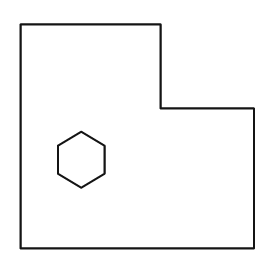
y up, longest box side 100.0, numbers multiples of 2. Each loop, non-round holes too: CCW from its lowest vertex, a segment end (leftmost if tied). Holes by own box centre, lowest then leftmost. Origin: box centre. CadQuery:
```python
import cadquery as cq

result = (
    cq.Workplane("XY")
    .moveTo(-50.0, -48.0)
    .lineTo(50.0, -48.0)
    .lineTo(50.0, 12.0)
    .lineTo(10.0, 12.0)
    .lineTo(10.0, 48.0)
    .lineTo(-50.0, 48.0)
    .close()
    .moveTo(-24.0, -22.0)
    .lineTo(-14.0, -16.0)
    .lineTo(-14.0, -4.0)
    .lineTo(-24.0, 2.0)
    .lineTo(-34.0, -4.0)
    .lineTo(-34.0, -16.0)
    .close()
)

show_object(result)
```